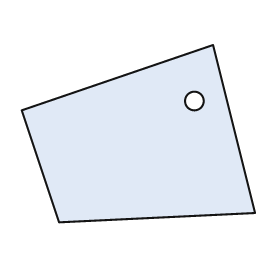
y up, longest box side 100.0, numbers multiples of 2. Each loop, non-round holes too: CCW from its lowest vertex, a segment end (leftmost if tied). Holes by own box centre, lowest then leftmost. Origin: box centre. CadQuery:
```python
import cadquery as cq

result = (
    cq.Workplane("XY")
    .moveTo(-34.0, -38.0)
    .lineTo(50.0, -34.0)
    .lineTo(32.0, 38.0)
    .lineTo(-50.0, 10.0)
    .close()
    .moveTo(24.0, 14.0)
    .circle(4.0)
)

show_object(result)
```